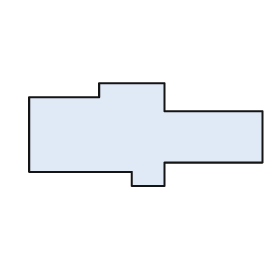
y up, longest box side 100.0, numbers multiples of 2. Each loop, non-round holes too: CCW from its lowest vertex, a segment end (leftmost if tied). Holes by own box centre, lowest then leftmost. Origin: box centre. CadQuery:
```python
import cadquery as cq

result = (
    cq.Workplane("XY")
    .moveTo(-6.0, -22.0)
    .lineTo(8.0, -22.0)
    .lineTo(8.0, -12.0)
    .lineTo(50.0, -12.0)
    .lineTo(50.0, 10.0)
    .lineTo(8.0, 10.0)
    .lineTo(8.0, 22.0)
    .lineTo(-20.0, 22.0)
    .lineTo(-20.0, 16.0)
    .lineTo(-50.0, 16.0)
    .lineTo(-50.0, -16.0)
    .lineTo(-6.0, -16.0)
    .close()
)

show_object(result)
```